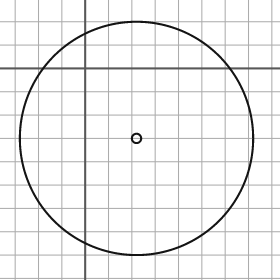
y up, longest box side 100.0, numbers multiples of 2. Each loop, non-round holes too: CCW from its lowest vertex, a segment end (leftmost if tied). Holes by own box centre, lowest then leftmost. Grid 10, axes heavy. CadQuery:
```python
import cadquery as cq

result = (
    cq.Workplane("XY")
    .moveTo(22.0, -30.0)
    .circle(50.0)
    .moveTo(22.0, -30.0)
    .circle(2.0)
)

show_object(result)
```